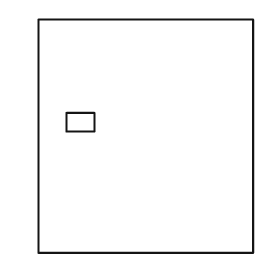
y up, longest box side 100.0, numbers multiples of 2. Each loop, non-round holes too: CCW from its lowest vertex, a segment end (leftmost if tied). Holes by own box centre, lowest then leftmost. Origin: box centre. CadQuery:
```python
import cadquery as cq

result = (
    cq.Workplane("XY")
    .moveTo(-46.0, -50.0)
    .lineTo(46.0, -50.0)
    .lineTo(46.0, 50.0)
    .lineTo(-46.0, 50.0)
    .close()
    .moveTo(-34.0, 2.0)
    .lineTo(-22.0, 2.0)
    .lineTo(-22.0, 10.0)
    .lineTo(-34.0, 10.0)
    .close()
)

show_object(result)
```